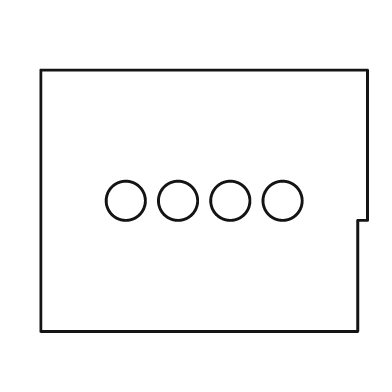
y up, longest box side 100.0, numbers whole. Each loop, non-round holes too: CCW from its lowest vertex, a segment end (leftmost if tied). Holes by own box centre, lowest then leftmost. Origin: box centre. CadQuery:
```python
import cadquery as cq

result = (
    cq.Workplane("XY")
    .moveTo(-50.0, -40.0)
    .lineTo(47.0, -40.0)
    .lineTo(47.0, -6.0)
    .lineTo(50.0, -6.0)
    .lineTo(50.0, 40.0)
    .lineTo(-50.0, 40.0)
    .close()
    .moveTo(-24.0, 0.0)
    .circle(6.0)
    .moveTo(-8.0, 0.0)
    .circle(6.0)
    .moveTo(8.0, 0.0)
    .circle(6.0)
    .moveTo(24.0, 0.0)
    .circle(6.0)
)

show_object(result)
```